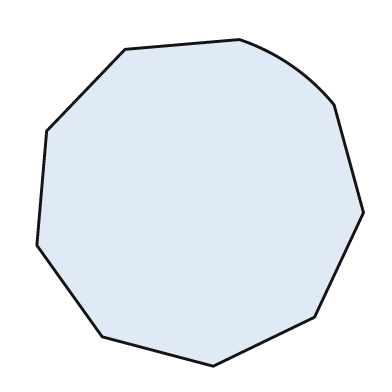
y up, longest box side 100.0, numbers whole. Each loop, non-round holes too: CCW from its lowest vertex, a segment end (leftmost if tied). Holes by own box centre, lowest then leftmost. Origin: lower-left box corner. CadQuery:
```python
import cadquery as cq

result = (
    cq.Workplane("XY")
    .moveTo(54.0, 0.0)
    .lineTo(85.0, 15.0)
    .lineTo(100.0, 47.0)
    .lineTo(91.0, 80.0)
    .threePointArc((78.0, 92.0), (62.0, 100.0))
    .lineTo(27.0, 97.0)
    .lineTo(3.0, 72.0)
    .lineTo(0.0, 37.0)
    .lineTo(20.0, 9.0)
    .close()
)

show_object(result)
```